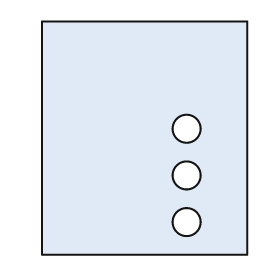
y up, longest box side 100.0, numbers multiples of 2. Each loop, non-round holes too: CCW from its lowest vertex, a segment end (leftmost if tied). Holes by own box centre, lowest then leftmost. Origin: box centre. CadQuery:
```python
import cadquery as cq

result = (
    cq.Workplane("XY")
    .moveTo(-44.0, -50.0)
    .lineTo(44.0, -50.0)
    .lineTo(44.0, 50.0)
    .lineTo(-44.0, 50.0)
    .close()
    .moveTo(18.0, -36.0)
    .circle(6.0)
    .moveTo(18.0, -16.0)
    .circle(6.0)
    .moveTo(18.0, 4.0)
    .circle(6.0)
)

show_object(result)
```